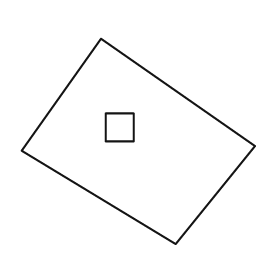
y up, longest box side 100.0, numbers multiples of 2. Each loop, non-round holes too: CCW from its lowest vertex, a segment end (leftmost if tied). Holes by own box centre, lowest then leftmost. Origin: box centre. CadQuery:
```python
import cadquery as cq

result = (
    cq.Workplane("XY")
    .moveTo(16.0, -44.0)
    .lineTo(50.0, -2.0)
    .lineTo(-16.0, 44.0)
    .lineTo(-50.0, -4.0)
    .close()
    .moveTo(-14.0, 0.0)
    .lineTo(-2.0, 0.0)
    .lineTo(-2.0, 12.0)
    .lineTo(-14.0, 12.0)
    .close()
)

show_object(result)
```